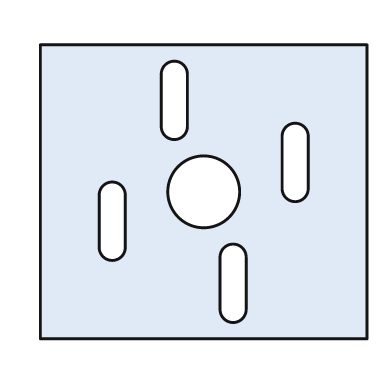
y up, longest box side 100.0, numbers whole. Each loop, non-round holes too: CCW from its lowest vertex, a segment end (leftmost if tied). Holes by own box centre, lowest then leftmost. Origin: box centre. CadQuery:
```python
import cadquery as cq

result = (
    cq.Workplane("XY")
    .moveTo(-50.0, -45.0)
    .lineTo(50.0, -45.0)
    .lineTo(50.0, 45.0)
    .lineTo(-50.0, 45.0)
    .close()
    .moveTo(5.0, -36.0)
    .threePointArc((9.0, -40.0), (13.0, -36.0))
    .lineTo(13.0, -20.0)
    .threePointArc((9.0, -16.0), (5.0, -20.0))
    .close()
    .moveTo(-32.0, -17.0)
    .threePointArc((-28.0, -21.0), (-24.0, -17.0))
    .lineTo(-24.0, -1.0)
    .threePointArc((-28.0, 3.0), (-32.0, -1.0))
    .close()
    .moveTo(0.0, 0.0)
    .circle(11.0)
    .moveTo(24.0, 1.0)
    .threePointArc((28.0, -3.0), (32.0, 1.0))
    .lineTo(32.0, 17.0)
    .threePointArc((28.0, 21.0), (24.0, 17.0))
    .close()
    .moveTo(-13.0, 20.0)
    .threePointArc((-9.0, 16.0), (-5.0, 20.0))
    .lineTo(-5.0, 36.0)
    .threePointArc((-9.0, 40.0), (-13.0, 36.0))
    .close()
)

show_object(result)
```